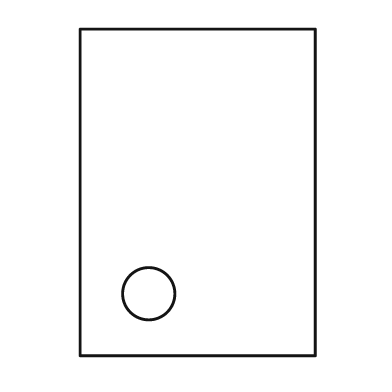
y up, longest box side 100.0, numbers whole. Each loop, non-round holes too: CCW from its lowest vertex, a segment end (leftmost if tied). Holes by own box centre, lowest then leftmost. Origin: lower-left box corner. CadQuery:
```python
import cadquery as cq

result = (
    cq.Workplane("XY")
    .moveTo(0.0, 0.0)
    .lineTo(72.0, 0.0)
    .lineTo(72.0, 100.0)
    .lineTo(0.0, 100.0)
    .close()
    .moveTo(21.0, 19.0)
    .circle(8.0)
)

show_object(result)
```